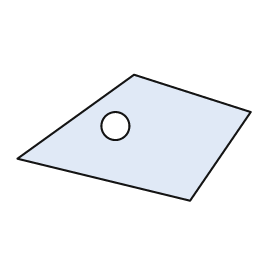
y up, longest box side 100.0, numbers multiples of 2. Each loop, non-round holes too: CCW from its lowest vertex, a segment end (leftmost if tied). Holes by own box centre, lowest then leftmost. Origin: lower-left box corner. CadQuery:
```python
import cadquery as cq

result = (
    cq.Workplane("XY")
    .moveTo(74.0, 0.0)
    .lineTo(100.0, 38.0)
    .lineTo(50.0, 54.0)
    .lineTo(0.0, 18.0)
    .close()
    .moveTo(42.0, 32.0)
    .circle(6.0)
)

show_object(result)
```